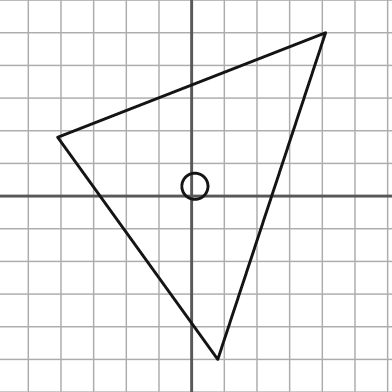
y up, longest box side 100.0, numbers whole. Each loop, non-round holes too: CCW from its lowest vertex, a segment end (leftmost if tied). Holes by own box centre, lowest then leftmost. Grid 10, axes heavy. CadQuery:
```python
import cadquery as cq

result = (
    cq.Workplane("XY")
    .moveTo(8.0, -50.0)
    .lineTo(41.0, 50.0)
    .lineTo(-41.0, 18.0)
    .close()
    .moveTo(1.0, 3.0)
    .circle(4.0)
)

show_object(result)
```